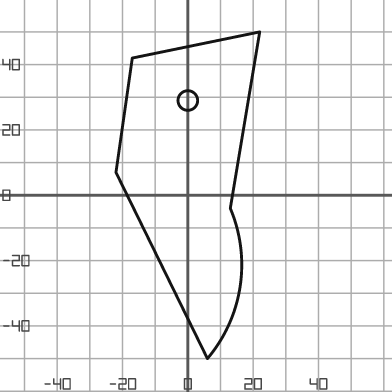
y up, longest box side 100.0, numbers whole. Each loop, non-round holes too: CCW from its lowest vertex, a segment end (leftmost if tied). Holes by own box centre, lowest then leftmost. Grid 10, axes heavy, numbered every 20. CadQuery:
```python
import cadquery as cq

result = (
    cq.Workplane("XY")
    .moveTo(6.0, -50.0)
    .threePointArc((16.0, -28.0), (13.0, -4.0))
    .lineTo(22.0, 50.0)
    .lineTo(-17.0, 42.0)
    .lineTo(-22.0, 7.0)
    .close()
    .moveTo(0.0, 29.0)
    .circle(3.0)
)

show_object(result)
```